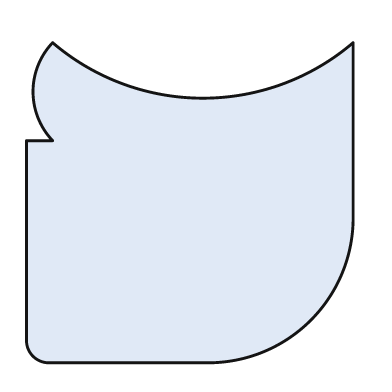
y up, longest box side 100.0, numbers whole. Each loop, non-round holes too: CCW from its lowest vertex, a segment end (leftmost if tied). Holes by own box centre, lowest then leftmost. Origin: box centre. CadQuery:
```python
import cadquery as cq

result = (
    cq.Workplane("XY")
    .moveTo(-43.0, -49.0)
    .lineTo(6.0, -49.0)
    .threePointArc((37.0, -36.0), (50.0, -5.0))
    .lineTo(50.0, 49.0)
    .threePointArc((4.0, 32.0), (-42.0, 49.0))
    .threePointArc((-48.0, 34.0), (-42.0, 19.0))
    .lineTo(-50.0, 19.0)
    .lineTo(-50.0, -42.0)
    .threePointArc((-48.0, -47.0), (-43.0, -49.0))
    .close()
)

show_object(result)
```